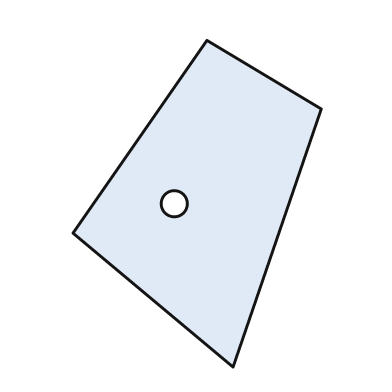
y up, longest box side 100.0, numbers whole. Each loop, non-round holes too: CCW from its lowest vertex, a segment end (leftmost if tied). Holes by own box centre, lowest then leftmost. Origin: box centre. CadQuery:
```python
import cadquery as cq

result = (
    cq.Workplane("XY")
    .moveTo(11.0, -50.0)
    .lineTo(38.0, 29.0)
    .lineTo(3.0, 50.0)
    .lineTo(-38.0, -9.0)
    .close()
    .moveTo(-7.0, 0.0)
    .circle(4.0)
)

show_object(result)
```